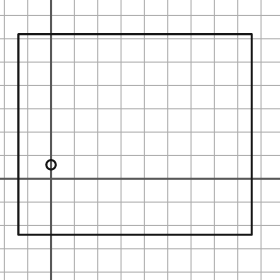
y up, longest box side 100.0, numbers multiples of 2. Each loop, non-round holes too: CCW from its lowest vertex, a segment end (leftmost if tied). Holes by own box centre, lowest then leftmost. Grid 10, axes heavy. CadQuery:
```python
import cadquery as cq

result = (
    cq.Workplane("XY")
    .moveTo(-14.0, -24.0)
    .lineTo(86.0, -24.0)
    .lineTo(86.0, 62.0)
    .lineTo(-14.0, 62.0)
    .close()
    .moveTo(0.0, 6.0)
    .circle(2.0)
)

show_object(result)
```